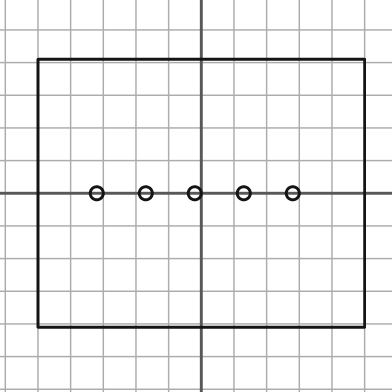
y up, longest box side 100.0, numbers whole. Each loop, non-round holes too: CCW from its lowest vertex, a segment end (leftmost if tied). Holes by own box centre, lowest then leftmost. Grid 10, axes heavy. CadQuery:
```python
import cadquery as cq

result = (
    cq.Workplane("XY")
    .moveTo(-50.0, -41.0)
    .lineTo(50.0, -41.0)
    .lineTo(50.0, 41.0)
    .lineTo(-50.0, 41.0)
    .close()
    .moveTo(-32.0, 0.0)
    .circle(2.0)
    .moveTo(-17.0, 0.0)
    .circle(2.0)
    .moveTo(-2.0, 0.0)
    .circle(2.0)
    .moveTo(13.0, 0.0)
    .circle(2.0)
    .moveTo(28.0, 0.0)
    .circle(2.0)
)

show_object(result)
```